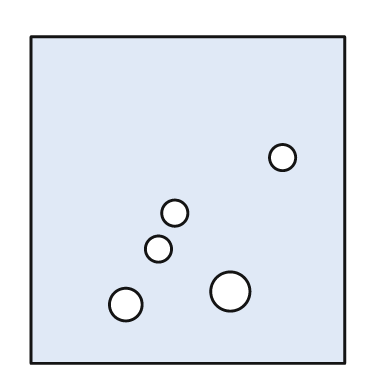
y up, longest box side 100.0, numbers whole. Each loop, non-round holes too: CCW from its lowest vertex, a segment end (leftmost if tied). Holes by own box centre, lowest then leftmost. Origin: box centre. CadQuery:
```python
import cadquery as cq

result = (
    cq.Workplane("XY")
    .moveTo(-48.0, -50.0)
    .lineTo(48.0, -50.0)
    .lineTo(48.0, 50.0)
    .lineTo(-48.0, 50.0)
    .close()
    .moveTo(-19.0, -32.0)
    .circle(5.0)
    .moveTo(13.0, -28.0)
    .circle(6.0)
    .moveTo(-9.0, -15.0)
    .circle(4.0)
    .moveTo(-4.0, -4.0)
    .circle(4.0)
    .moveTo(29.0, 13.0)
    .circle(4.0)
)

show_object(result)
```